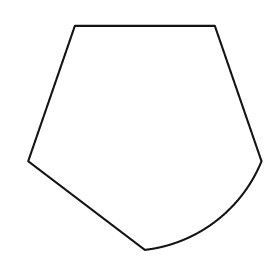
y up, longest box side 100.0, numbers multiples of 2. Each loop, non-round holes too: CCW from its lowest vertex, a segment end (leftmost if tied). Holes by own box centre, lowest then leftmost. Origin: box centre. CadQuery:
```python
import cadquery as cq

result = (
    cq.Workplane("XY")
    .moveTo(0.0, -48.0)
    .threePointArc((30.0, -36.0), (50.0, -10.0))
    .lineTo(30.0, 48.0)
    .lineTo(-30.0, 48.0)
    .lineTo(-50.0, -10.0)
    .close()
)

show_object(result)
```